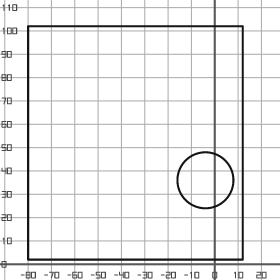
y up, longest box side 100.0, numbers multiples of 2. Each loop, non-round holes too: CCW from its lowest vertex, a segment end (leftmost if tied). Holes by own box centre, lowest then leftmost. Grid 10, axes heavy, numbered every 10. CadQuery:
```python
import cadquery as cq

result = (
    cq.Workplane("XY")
    .moveTo(-80.0, 2.0)
    .lineTo(12.0, 2.0)
    .lineTo(12.0, 102.0)
    .lineTo(-80.0, 102.0)
    .close()
    .moveTo(-4.0, 36.0)
    .circle(12.0)
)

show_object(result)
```